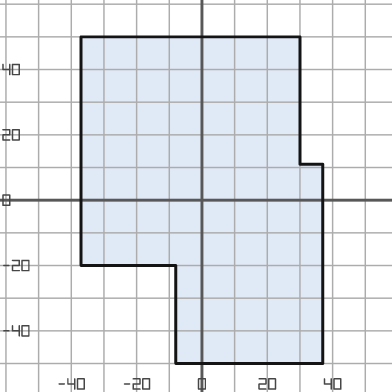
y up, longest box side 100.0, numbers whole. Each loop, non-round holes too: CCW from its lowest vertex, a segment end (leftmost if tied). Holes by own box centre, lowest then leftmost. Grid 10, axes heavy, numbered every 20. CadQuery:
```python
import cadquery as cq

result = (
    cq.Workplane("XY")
    .moveTo(-8.0, -50.0)
    .lineTo(37.0, -50.0)
    .lineTo(37.0, 11.0)
    .lineTo(30.0, 11.0)
    .lineTo(30.0, 50.0)
    .lineTo(-37.0, 50.0)
    .lineTo(-37.0, -20.0)
    .lineTo(-8.0, -20.0)
    .close()
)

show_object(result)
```